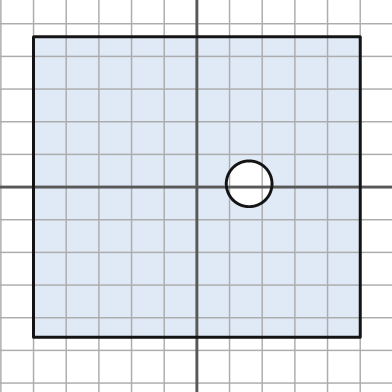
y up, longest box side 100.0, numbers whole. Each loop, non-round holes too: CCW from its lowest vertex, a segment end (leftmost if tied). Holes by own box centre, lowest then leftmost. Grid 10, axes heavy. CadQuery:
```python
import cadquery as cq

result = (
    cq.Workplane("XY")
    .moveTo(-50.0, -46.0)
    .lineTo(50.0, -46.0)
    .lineTo(50.0, 46.0)
    .lineTo(-50.0, 46.0)
    .close()
    .moveTo(16.0, 1.0)
    .circle(7.0)
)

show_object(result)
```